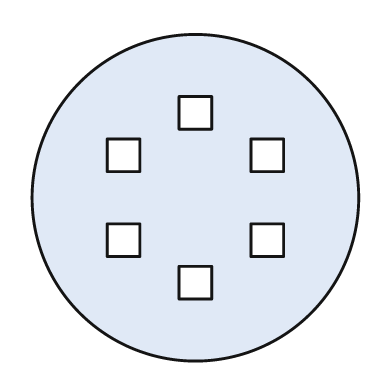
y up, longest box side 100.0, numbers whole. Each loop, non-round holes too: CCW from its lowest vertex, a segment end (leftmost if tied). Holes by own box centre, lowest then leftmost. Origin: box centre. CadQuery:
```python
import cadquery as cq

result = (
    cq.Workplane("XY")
    .moveTo(0.0, 0.0)
    .circle(50.0)
    .moveTo(-5.0, -31.0)
    .lineTo(5.0, -31.0)
    .lineTo(5.0, -21.0)
    .lineTo(-5.0, -21.0)
    .close()
    .moveTo(-27.0, -18.0)
    .lineTo(-17.0, -18.0)
    .lineTo(-17.0, -8.0)
    .lineTo(-27.0, -8.0)
    .close()
    .moveTo(17.0, -18.0)
    .lineTo(27.0, -18.0)
    .lineTo(27.0, -8.0)
    .lineTo(17.0, -8.0)
    .close()
    .moveTo(-27.0, 8.0)
    .lineTo(-17.0, 8.0)
    .lineTo(-17.0, 18.0)
    .lineTo(-27.0, 18.0)
    .close()
    .moveTo(17.0, 8.0)
    .lineTo(27.0, 8.0)
    .lineTo(27.0, 18.0)
    .lineTo(17.0, 18.0)
    .close()
    .moveTo(-5.0, 21.0)
    .lineTo(5.0, 21.0)
    .lineTo(5.0, 31.0)
    .lineTo(-5.0, 31.0)
    .close()
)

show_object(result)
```